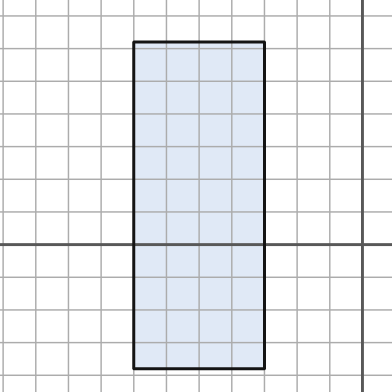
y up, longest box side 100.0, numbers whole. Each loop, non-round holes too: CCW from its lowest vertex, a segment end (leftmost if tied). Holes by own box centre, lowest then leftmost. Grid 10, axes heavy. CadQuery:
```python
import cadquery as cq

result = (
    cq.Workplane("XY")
    .moveTo(-70.0, -38.0)
    .lineTo(-30.0, -38.0)
    .lineTo(-30.0, 62.0)
    .lineTo(-70.0, 62.0)
    .close()
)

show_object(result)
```